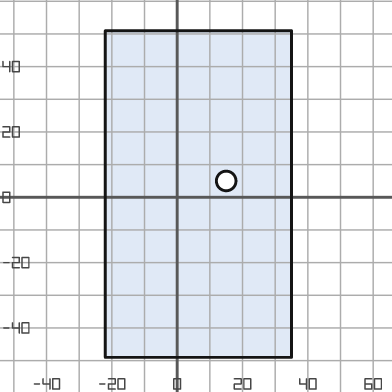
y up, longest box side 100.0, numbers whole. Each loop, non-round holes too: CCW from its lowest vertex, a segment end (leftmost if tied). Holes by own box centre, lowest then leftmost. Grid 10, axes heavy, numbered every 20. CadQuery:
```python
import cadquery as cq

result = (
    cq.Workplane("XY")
    .moveTo(-22.0, -49.0)
    .lineTo(35.0, -49.0)
    .lineTo(35.0, 51.0)
    .lineTo(-22.0, 51.0)
    .close()
    .moveTo(15.0, 5.0)
    .circle(3.0)
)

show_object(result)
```